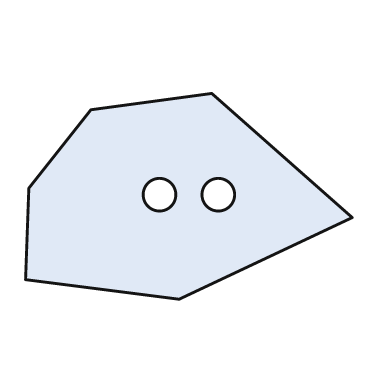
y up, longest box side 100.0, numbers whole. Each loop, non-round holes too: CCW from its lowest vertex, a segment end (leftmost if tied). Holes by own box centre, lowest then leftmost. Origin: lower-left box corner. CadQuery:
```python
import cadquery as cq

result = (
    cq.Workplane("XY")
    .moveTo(47.0, 0.0)
    .lineTo(100.0, 25.0)
    .lineTo(57.0, 63.0)
    .lineTo(20.0, 58.0)
    .lineTo(1.0, 34.0)
    .lineTo(0.0, 6.0)
    .close()
    .moveTo(41.0, 32.0)
    .circle(5.0)
    .moveTo(59.0, 32.0)
    .circle(5.0)
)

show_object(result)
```